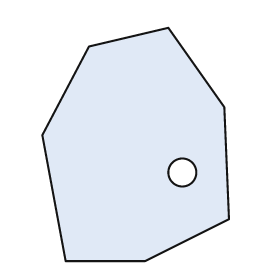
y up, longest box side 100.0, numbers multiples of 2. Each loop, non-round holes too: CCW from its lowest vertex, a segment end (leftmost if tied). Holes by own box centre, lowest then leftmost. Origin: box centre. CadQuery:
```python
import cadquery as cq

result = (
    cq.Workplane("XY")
    .moveTo(-30.0, -50.0)
    .lineTo(4.0, -50.0)
    .lineTo(40.0, -32.0)
    .lineTo(38.0, 16.0)
    .lineTo(14.0, 50.0)
    .lineTo(-20.0, 42.0)
    .lineTo(-40.0, 4.0)
    .close()
    .moveTo(20.0, -12.0)
    .circle(6.0)
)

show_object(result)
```